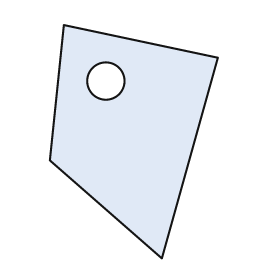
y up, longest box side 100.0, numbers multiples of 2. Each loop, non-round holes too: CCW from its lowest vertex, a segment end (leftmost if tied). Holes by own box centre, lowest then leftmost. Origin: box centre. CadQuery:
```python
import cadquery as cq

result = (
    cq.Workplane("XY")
    .moveTo(12.0, -50.0)
    .lineTo(36.0, 36.0)
    .lineTo(-30.0, 50.0)
    .lineTo(-36.0, -8.0)
    .close()
    .moveTo(-12.0, 26.0)
    .circle(8.0)
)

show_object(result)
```